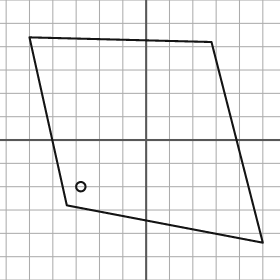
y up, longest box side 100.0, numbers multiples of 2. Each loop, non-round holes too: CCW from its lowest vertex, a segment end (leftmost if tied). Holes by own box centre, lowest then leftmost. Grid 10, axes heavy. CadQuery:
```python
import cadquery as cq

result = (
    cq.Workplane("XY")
    .moveTo(50.0, -44.0)
    .lineTo(28.0, 42.0)
    .lineTo(-50.0, 44.0)
    .lineTo(-34.0, -28.0)
    .close()
    .moveTo(-28.0, -20.0)
    .circle(2.0)
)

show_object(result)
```